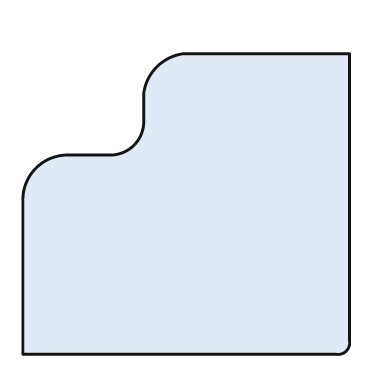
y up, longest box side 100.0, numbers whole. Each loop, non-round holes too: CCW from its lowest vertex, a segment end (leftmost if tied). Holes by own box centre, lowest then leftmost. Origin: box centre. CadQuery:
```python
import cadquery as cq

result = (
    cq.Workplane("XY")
    .moveTo(-50.0, -46.0)
    .lineTo(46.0, -46.0)
    .threePointArc((49.0, -45.0), (50.0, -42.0))
    .lineTo(50.0, 46.0)
    .lineTo(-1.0, 46.0)
    .threePointArc((-9.0, 42.0), (-13.0, 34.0))
    .lineTo(-13.0, 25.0)
    .threePointArc((-16.0, 18.0), (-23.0, 15.0))
    .lineTo(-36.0, 15.0)
    .threePointArc((-46.0, 11.0), (-50.0, 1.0))
    .close()
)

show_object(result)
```